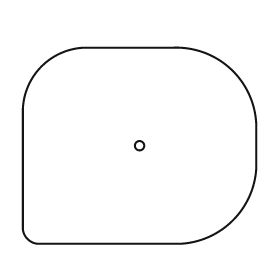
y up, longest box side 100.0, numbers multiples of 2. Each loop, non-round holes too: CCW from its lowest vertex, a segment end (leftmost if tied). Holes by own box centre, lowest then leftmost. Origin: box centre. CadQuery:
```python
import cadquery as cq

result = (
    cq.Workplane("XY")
    .moveTo(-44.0, -42.0)
    .lineTo(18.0, -42.0)
    .threePointArc((40.0, -32.0), (50.0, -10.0))
    .lineTo(50.0, 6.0)
    .threePointArc((40.0, 32.0), (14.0, 42.0))
    .lineTo(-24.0, 42.0)
    .threePointArc((-42.0, 34.0), (-50.0, 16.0))
    .lineTo(-50.0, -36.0)
    .threePointArc((-48.0, -40.0), (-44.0, -42.0))
    .close()
    .moveTo(0.0, 0.0)
    .circle(2.0)
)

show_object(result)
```